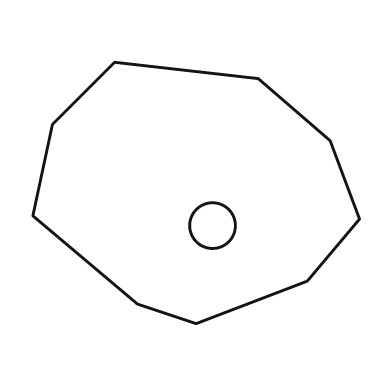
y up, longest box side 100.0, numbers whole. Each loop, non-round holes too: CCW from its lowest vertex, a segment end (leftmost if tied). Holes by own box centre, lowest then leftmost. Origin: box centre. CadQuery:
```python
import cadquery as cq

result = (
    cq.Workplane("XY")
    .moveTo(0.0, -40.0)
    .lineTo(34.0, -27.0)
    .lineTo(50.0, -8.0)
    .lineTo(41.0, 16.0)
    .lineTo(19.0, 35.0)
    .lineTo(-25.0, 40.0)
    .lineTo(-44.0, 21.0)
    .lineTo(-50.0, -7.0)
    .lineTo(-18.0, -34.0)
    .close()
    .moveTo(5.0, -10.0)
    .circle(7.0)
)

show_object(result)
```